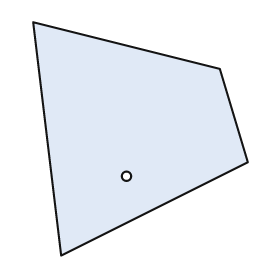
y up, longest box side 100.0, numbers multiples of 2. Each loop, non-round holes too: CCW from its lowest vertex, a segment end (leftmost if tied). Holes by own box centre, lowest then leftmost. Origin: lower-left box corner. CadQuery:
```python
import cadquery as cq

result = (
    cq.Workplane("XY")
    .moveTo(12.0, 0.0)
    .lineTo(92.0, 40.0)
    .lineTo(80.0, 80.0)
    .lineTo(0.0, 100.0)
    .close()
    .moveTo(40.0, 34.0)
    .circle(2.0)
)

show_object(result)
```